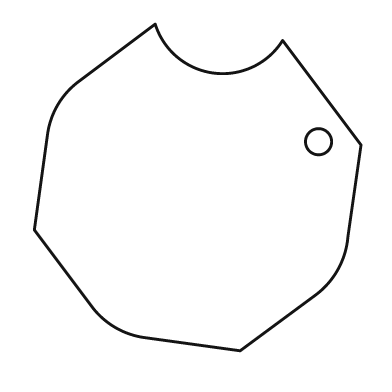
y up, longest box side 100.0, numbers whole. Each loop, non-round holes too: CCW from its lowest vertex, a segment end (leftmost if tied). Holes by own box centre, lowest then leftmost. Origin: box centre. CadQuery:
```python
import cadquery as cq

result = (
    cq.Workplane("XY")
    .moveTo(13.0, -50.0)
    .lineTo(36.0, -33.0)
    .threePointArc((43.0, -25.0), (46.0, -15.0))
    .lineTo(50.0, 13.0)
    .lineTo(26.0, 45.0)
    .threePointArc((5.0, 35.0), (-13.0, 50.0))
    .lineTo(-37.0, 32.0)
    .threePointArc((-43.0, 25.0), (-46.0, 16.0))
    .lineTo(-50.0, -13.0)
    .lineTo(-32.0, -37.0)
    .threePointArc((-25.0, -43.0), (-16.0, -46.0))
    .close()
    .moveTo(37.0, 14.0)
    .circle(4.0)
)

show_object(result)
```